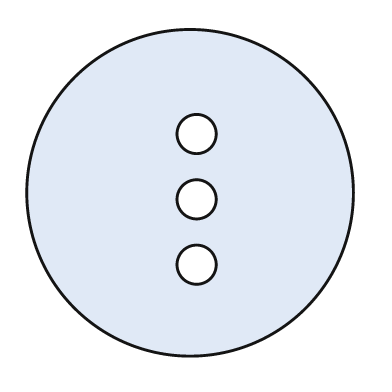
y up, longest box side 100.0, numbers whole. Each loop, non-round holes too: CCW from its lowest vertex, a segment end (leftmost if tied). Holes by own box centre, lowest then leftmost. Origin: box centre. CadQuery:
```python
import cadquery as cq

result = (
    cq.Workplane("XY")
    .moveTo(0.0, 0.0)
    .circle(50.0)
    .moveTo(2.0, -22.0)
    .circle(6.0)
    .moveTo(2.0, -2.0)
    .circle(6.0)
    .moveTo(2.0, 18.0)
    .circle(6.0)
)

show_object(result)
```